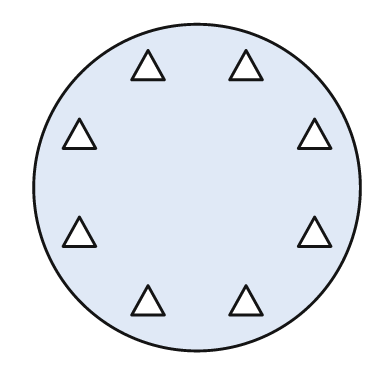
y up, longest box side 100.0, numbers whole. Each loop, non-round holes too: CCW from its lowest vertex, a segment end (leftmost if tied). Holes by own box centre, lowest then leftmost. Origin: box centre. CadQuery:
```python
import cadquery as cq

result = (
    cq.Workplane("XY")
    .moveTo(0.0, 0.0)
    .circle(50.0)
    .moveTo(-20.0, -39.0)
    .lineTo(-10.0, -39.0)
    .lineTo(-15.0, -30.0)
    .close()
    .moveTo(10.0, -39.0)
    .lineTo(20.0, -39.0)
    .lineTo(15.0, -30.0)
    .close()
    .moveTo(-41.0, -18.0)
    .lineTo(-31.0, -18.0)
    .lineTo(-36.0, -9.0)
    .close()
    .moveTo(31.0, -18.0)
    .lineTo(41.0, -18.0)
    .lineTo(36.0, -9.0)
    .close()
    .moveTo(-41.0, 12.0)
    .lineTo(-31.0, 12.0)
    .lineTo(-36.0, 21.0)
    .close()
    .moveTo(31.0, 12.0)
    .lineTo(41.0, 12.0)
    .lineTo(36.0, 21.0)
    .close()
    .moveTo(-20.0, 33.0)
    .lineTo(-10.0, 33.0)
    .lineTo(-15.0, 42.0)
    .close()
    .moveTo(10.0, 33.0)
    .lineTo(20.0, 33.0)
    .lineTo(15.0, 42.0)
    .close()
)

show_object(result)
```